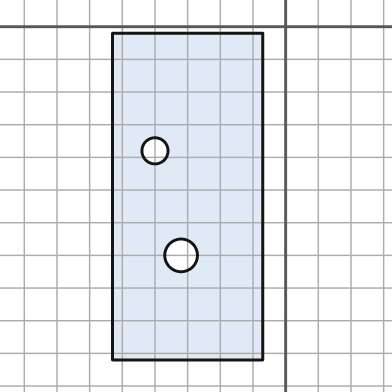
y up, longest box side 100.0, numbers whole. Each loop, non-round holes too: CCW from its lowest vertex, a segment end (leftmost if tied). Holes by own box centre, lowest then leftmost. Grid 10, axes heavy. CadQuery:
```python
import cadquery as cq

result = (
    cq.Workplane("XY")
    .moveTo(-53.0, -102.0)
    .lineTo(-7.0, -102.0)
    .lineTo(-7.0, -2.0)
    .lineTo(-53.0, -2.0)
    .close()
    .moveTo(-32.0, -70.0)
    .circle(5.0)
    .moveTo(-40.0, -38.0)
    .circle(4.0)
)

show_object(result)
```